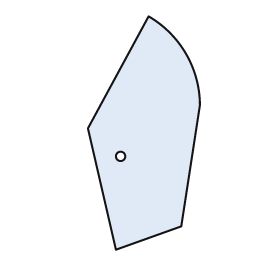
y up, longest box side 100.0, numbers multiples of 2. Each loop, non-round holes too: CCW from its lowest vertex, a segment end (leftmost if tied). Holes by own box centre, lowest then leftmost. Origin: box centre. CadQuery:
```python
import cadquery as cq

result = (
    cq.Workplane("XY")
    .moveTo(-12.0, -50.0)
    .lineTo(16.0, -40.0)
    .lineTo(24.0, 12.0)
    .threePointArc((18.0, 34.0), (2.0, 50.0))
    .lineTo(-24.0, 2.0)
    .close()
    .moveTo(-10.0, -10.0)
    .circle(2.0)
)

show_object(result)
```